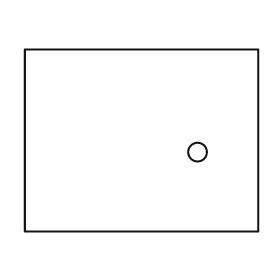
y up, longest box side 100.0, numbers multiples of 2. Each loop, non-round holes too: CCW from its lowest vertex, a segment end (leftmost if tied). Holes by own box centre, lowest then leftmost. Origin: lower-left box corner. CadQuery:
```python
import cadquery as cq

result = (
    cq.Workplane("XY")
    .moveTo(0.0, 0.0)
    .lineTo(100.0, 0.0)
    .lineTo(100.0, 78.0)
    .lineTo(0.0, 78.0)
    .close()
    .moveTo(74.0, 34.0)
    .circle(4.0)
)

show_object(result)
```